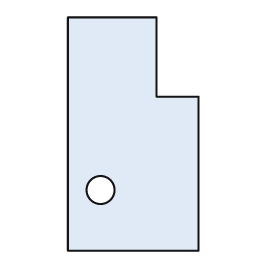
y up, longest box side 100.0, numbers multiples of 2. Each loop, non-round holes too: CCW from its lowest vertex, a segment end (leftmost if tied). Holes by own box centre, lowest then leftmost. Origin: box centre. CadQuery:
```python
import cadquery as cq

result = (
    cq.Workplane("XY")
    .moveTo(-28.0, -50.0)
    .lineTo(28.0, -50.0)
    .lineTo(28.0, 16.0)
    .lineTo(10.0, 16.0)
    .lineTo(10.0, 50.0)
    .lineTo(-28.0, 50.0)
    .close()
    .moveTo(-14.0, -24.0)
    .circle(6.0)
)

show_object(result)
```